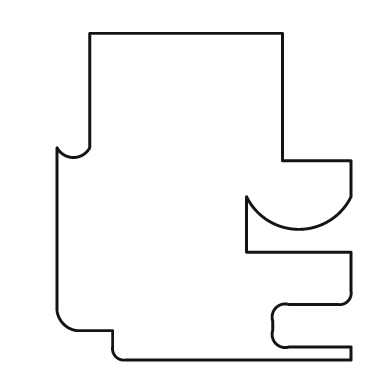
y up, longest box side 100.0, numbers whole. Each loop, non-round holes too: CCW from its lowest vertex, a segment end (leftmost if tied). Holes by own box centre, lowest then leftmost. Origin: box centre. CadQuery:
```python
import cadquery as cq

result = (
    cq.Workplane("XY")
    .moveTo(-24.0, -50.0)
    .lineTo(45.0, -50.0)
    .lineTo(45.0, -46.0)
    .lineTo(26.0, -46.0)
    .threePointArc((22.0, -45.0), (21.0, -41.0))
    .lineTo(21.0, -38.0)
    .threePointArc((22.0, -34.0), (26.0, -33.0))
    .lineTo(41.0, -33.0)
    .threePointArc((44.0, -32.0), (45.0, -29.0))
    .lineTo(45.0, -17.0)
    .lineTo(13.0, -17.0)
    .lineTo(13.0, 0.0)
    .threePointArc((29.0, -10.0), (45.0, 0.0))
    .lineTo(45.0, 11.0)
    .lineTo(24.0, 11.0)
    .lineTo(24.0, 50.0)
    .lineTo(-35.0, 50.0)
    .lineTo(-35.0, 15.0)
    .threePointArc((-40.0, 12.0), (-45.0, 15.0))
    .lineTo(-45.0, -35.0)
    .threePointArc((-43.0, -39.0), (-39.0, -41.0))
    .lineTo(-28.0, -41.0)
    .lineTo(-28.0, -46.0)
    .threePointArc((-27.0, -49.0), (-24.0, -50.0))
    .close()
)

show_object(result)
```